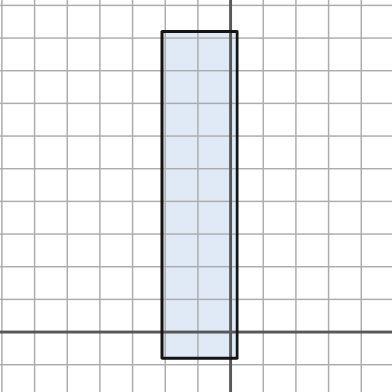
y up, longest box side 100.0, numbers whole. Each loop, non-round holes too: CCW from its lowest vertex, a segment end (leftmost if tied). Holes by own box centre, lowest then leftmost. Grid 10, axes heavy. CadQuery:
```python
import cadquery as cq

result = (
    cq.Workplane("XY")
    .moveTo(-21.0, -8.0)
    .lineTo(2.0, -8.0)
    .lineTo(2.0, 92.0)
    .lineTo(-21.0, 92.0)
    .close()
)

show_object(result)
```